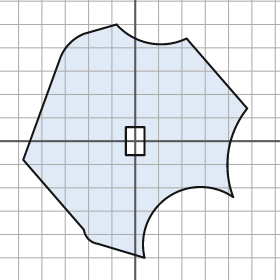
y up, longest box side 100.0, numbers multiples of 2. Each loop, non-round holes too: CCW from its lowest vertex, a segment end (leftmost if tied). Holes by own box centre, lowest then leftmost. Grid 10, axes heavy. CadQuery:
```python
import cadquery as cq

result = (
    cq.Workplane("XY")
    .moveTo(4.0, -50.0)
    .threePointArc((14.0, -24.0), (42.0, -24.0))
    .threePointArc((40.0, -4.0), (48.0, 14.0))
    .lineTo(22.0, 44.0)
    .threePointArc((6.0, 42.0), (-8.0, 50.0))
    .lineTo(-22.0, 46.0)
    .threePointArc((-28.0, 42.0), (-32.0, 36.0))
    .lineTo(-48.0, -8.0)
    .lineTo(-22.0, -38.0)
    .threePointArc((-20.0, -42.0), (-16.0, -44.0))
    .close()
    .moveTo(-4.0, -6.0)
    .lineTo(4.0, -6.0)
    .lineTo(4.0, 6.0)
    .lineTo(-4.0, 6.0)
    .close()
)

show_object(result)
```